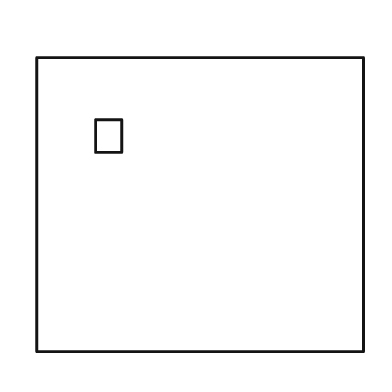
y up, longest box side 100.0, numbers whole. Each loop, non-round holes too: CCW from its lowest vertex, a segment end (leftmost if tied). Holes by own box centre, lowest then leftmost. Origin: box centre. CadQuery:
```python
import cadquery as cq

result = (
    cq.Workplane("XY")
    .moveTo(-50.0, -45.0)
    .lineTo(50.0, -45.0)
    .lineTo(50.0, 45.0)
    .lineTo(-50.0, 45.0)
    .close()
    .moveTo(-32.0, 16.0)
    .lineTo(-24.0, 16.0)
    .lineTo(-24.0, 26.0)
    .lineTo(-32.0, 26.0)
    .close()
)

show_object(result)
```